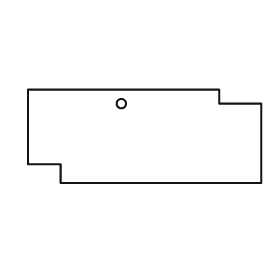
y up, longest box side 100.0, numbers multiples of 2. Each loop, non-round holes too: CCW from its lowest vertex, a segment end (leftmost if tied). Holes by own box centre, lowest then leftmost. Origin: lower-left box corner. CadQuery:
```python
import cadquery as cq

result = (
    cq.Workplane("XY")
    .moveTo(14.0, 0.0)
    .lineTo(100.0, 0.0)
    .lineTo(100.0, 34.0)
    .lineTo(82.0, 34.0)
    .lineTo(82.0, 40.0)
    .lineTo(0.0, 40.0)
    .lineTo(0.0, 8.0)
    .lineTo(14.0, 8.0)
    .close()
    .moveTo(40.0, 34.0)
    .circle(2.0)
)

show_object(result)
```